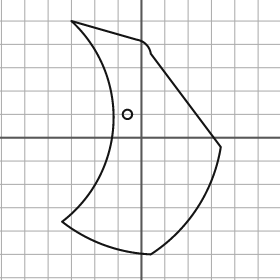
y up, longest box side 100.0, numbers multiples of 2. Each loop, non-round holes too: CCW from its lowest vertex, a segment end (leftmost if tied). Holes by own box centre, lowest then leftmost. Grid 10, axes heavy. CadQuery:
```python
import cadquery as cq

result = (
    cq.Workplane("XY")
    .moveTo(4.0, -50.0)
    .threePointArc((24.0, -30.0), (34.0, -4.0))
    .lineTo(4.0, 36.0)
    .threePointArc((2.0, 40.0), (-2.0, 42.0))
    .lineTo(-30.0, 50.0)
    .threePointArc((-12.0, 6.0), (-34.0, -36.0))
    .threePointArc((-16.0, -46.0), (4.0, -50.0))
    .close()
    .moveTo(-6.0, 10.0)
    .circle(2.0)
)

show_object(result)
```